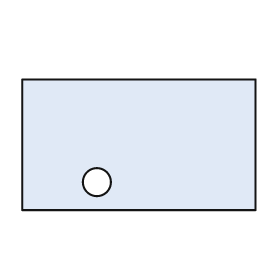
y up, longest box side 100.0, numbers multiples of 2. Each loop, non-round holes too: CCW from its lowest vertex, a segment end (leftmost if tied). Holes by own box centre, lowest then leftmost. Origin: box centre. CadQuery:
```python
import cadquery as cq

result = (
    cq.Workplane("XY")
    .moveTo(-50.0, -28.0)
    .lineTo(50.0, -28.0)
    .lineTo(50.0, 28.0)
    .lineTo(-50.0, 28.0)
    .close()
    .moveTo(-18.0, -16.0)
    .circle(6.0)
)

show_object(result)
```